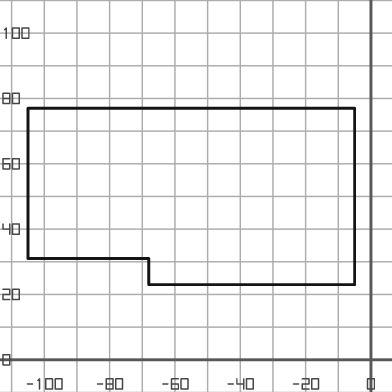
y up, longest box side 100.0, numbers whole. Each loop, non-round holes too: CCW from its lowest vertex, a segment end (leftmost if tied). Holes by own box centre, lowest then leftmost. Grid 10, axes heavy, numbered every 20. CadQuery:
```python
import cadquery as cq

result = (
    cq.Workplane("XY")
    .moveTo(-68.0, 23.0)
    .lineTo(-5.0, 23.0)
    .lineTo(-5.0, 77.0)
    .lineTo(-105.0, 77.0)
    .lineTo(-105.0, 31.0)
    .lineTo(-68.0, 31.0)
    .close()
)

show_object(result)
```